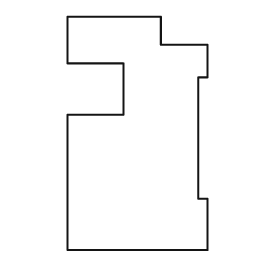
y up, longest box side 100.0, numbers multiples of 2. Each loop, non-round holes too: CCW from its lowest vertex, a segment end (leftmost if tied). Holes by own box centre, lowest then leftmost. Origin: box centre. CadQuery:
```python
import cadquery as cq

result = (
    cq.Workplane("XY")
    .moveTo(-30.0, -50.0)
    .lineTo(30.0, -50.0)
    .lineTo(30.0, -28.0)
    .lineTo(26.0, -28.0)
    .lineTo(26.0, 24.0)
    .lineTo(30.0, 24.0)
    .lineTo(30.0, 38.0)
    .lineTo(10.0, 38.0)
    .lineTo(10.0, 50.0)
    .lineTo(-30.0, 50.0)
    .lineTo(-30.0, 30.0)
    .lineTo(-6.0, 30.0)
    .lineTo(-6.0, 8.0)
    .lineTo(-30.0, 8.0)
    .close()
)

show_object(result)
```